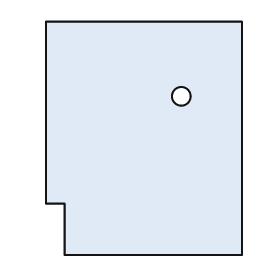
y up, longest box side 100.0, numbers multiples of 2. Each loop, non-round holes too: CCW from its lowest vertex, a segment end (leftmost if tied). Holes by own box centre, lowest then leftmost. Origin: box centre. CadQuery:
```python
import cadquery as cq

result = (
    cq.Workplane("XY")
    .moveTo(-34.0, -50.0)
    .lineTo(42.0, -50.0)
    .lineTo(42.0, 50.0)
    .lineTo(-42.0, 50.0)
    .lineTo(-42.0, -28.0)
    .lineTo(-34.0, -28.0)
    .close()
    .moveTo(16.0, 18.0)
    .circle(4.0)
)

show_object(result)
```